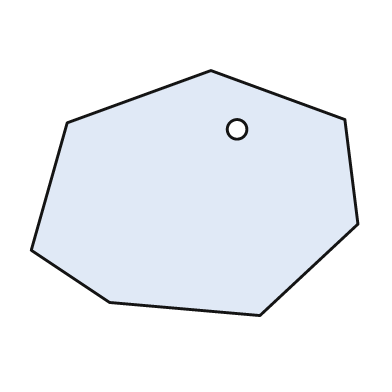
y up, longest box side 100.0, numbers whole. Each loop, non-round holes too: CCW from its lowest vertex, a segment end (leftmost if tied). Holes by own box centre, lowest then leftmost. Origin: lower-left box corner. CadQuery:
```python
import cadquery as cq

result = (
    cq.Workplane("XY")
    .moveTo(70.0, 0.0)
    .lineTo(100.0, 28.0)
    .lineTo(96.0, 60.0)
    .lineTo(55.0, 75.0)
    .lineTo(11.0, 59.0)
    .lineTo(0.0, 20.0)
    .lineTo(24.0, 4.0)
    .close()
    .moveTo(63.0, 57.0)
    .circle(3.0)
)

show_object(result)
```